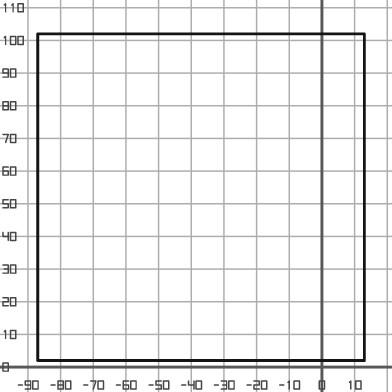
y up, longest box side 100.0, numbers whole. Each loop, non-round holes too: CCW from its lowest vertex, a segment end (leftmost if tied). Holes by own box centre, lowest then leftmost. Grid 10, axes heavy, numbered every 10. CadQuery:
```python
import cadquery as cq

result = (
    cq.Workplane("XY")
    .moveTo(-87.0, 2.0)
    .lineTo(13.0, 2.0)
    .lineTo(13.0, 102.0)
    .lineTo(-87.0, 102.0)
    .close()
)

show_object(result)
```